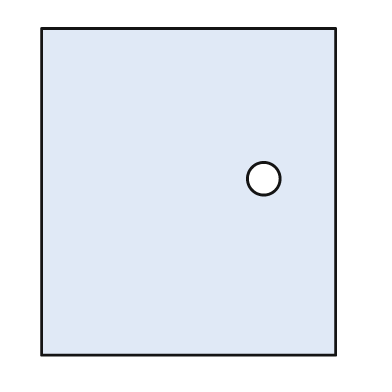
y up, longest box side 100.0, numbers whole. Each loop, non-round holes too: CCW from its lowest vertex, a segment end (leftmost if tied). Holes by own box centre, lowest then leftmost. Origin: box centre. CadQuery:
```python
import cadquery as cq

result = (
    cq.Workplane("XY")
    .moveTo(-45.0, -50.0)
    .lineTo(45.0, -50.0)
    .lineTo(45.0, 50.0)
    .lineTo(-45.0, 50.0)
    .close()
    .moveTo(23.0, 4.0)
    .circle(5.0)
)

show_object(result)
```